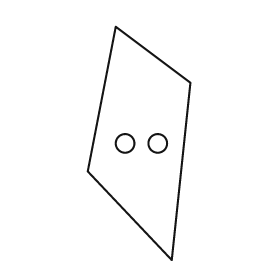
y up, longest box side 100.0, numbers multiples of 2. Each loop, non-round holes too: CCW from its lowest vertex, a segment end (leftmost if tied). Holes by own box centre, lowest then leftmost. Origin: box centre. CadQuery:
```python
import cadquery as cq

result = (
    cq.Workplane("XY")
    .moveTo(14.0, -50.0)
    .lineTo(22.0, 26.0)
    .lineTo(-10.0, 50.0)
    .lineTo(-22.0, -12.0)
    .close()
    .moveTo(-6.0, 0.0)
    .circle(4.0)
    .moveTo(8.0, 0.0)
    .circle(4.0)
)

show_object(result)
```